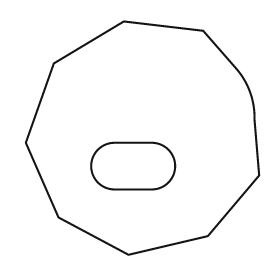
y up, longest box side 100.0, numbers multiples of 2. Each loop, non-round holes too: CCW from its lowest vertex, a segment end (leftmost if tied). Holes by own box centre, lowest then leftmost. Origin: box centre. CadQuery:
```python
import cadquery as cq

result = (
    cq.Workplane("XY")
    .moveTo(-6.0, -50.0)
    .lineTo(28.0, -42.0)
    .lineTo(50.0, -16.0)
    .lineTo(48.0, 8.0)
    .threePointArc((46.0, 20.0), (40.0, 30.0))
    .lineTo(26.0, 46.0)
    .lineTo(-8.0, 50.0)
    .lineTo(-38.0, 32.0)
    .lineTo(-50.0, -2.0)
    .lineTo(-36.0, -34.0)
    .close()
    .moveTo(-12.0, -22.0)
    .lineTo(4.0, -22.0)
    .threePointArc((14.0, -12.0), (4.0, -2.0))
    .lineTo(-12.0, -2.0)
    .threePointArc((-22.0, -12.0), (-12.0, -22.0))
    .close()
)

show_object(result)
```